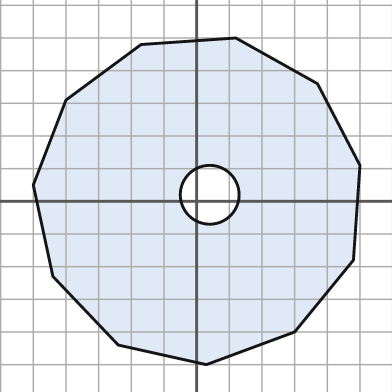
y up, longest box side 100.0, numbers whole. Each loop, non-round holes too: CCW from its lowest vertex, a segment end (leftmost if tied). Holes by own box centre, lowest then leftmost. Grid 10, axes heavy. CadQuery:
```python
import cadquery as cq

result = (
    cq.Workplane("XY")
    .moveTo(3.0, -50.0)
    .lineTo(30.0, -40.0)
    .lineTo(48.0, -18.0)
    .lineTo(50.0, 11.0)
    .lineTo(37.0, 36.0)
    .lineTo(12.0, 50.0)
    .lineTo(-17.0, 48.0)
    .lineTo(-40.0, 31.0)
    .lineTo(-50.0, 5.0)
    .lineTo(-44.0, -23.0)
    .lineTo(-24.0, -44.0)
    .close()
    .moveTo(4.0, 2.0)
    .circle(9.0)
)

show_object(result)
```